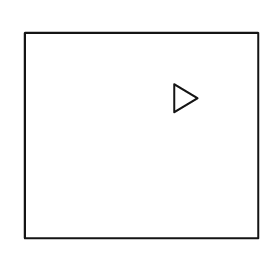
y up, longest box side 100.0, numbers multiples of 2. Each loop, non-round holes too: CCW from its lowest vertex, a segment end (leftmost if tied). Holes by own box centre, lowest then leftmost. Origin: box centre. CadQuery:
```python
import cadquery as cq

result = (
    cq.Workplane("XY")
    .moveTo(-50.0, -44.0)
    .lineTo(50.0, -44.0)
    .lineTo(50.0, 44.0)
    .lineTo(-50.0, 44.0)
    .close()
    .moveTo(14.0, 10.0)
    .lineTo(24.0, 16.0)
    .lineTo(14.0, 22.0)
    .close()
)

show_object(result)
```